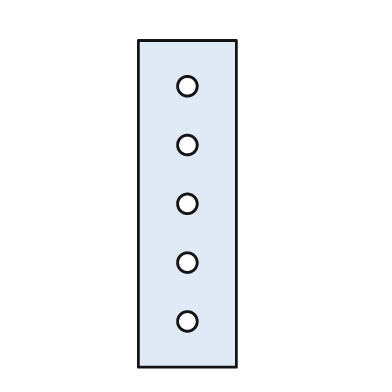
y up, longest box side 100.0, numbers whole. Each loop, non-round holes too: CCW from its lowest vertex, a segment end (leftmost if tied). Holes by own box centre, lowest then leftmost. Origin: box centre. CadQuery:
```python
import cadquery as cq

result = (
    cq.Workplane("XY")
    .moveTo(-15.0, -50.0)
    .lineTo(15.0, -50.0)
    .lineTo(15.0, 50.0)
    .lineTo(-15.0, 50.0)
    .close()
    .moveTo(0.0, -36.0)
    .circle(3.0)
    .moveTo(0.0, -18.0)
    .circle(3.0)
    .moveTo(0.0, 0.0)
    .circle(3.0)
    .moveTo(0.0, 18.0)
    .circle(3.0)
    .moveTo(0.0, 36.0)
    .circle(3.0)
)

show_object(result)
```